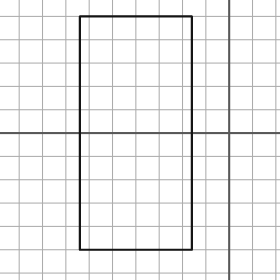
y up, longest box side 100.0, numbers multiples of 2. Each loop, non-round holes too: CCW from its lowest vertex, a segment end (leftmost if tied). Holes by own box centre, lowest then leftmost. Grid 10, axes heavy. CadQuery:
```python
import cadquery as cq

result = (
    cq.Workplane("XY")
    .moveTo(-64.0, -50.0)
    .lineTo(-16.0, -50.0)
    .lineTo(-16.0, 50.0)
    .lineTo(-64.0, 50.0)
    .close()
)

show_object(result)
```